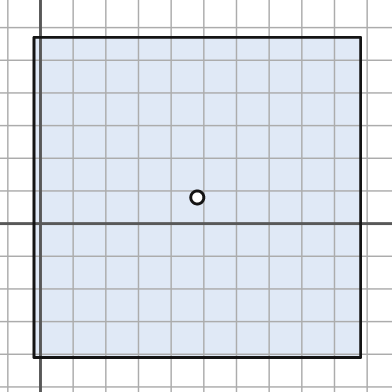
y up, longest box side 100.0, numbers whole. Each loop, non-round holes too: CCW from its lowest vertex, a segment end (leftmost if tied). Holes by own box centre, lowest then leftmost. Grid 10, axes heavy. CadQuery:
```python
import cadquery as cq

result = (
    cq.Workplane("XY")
    .moveTo(-2.0, -41.0)
    .lineTo(98.0, -41.0)
    .lineTo(98.0, 57.0)
    .lineTo(-2.0, 57.0)
    .close()
    .moveTo(48.0, 8.0)
    .circle(2.0)
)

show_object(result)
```